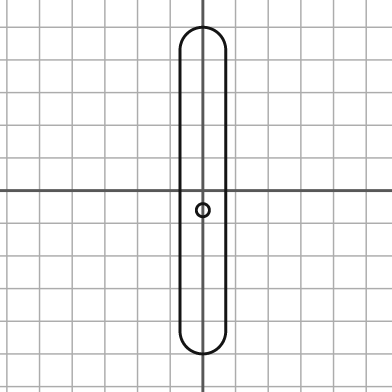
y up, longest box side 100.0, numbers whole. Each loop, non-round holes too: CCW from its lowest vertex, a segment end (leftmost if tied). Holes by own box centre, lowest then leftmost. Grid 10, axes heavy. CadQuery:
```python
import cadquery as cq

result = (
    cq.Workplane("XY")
    .moveTo(-7.0, -43.0)
    .threePointArc((0.0, -50.0), (7.0, -43.0))
    .lineTo(7.0, 43.0)
    .threePointArc((0.0, 50.0), (-7.0, 43.0))
    .close()
    .moveTo(0.0, -6.0)
    .circle(2.0)
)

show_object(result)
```